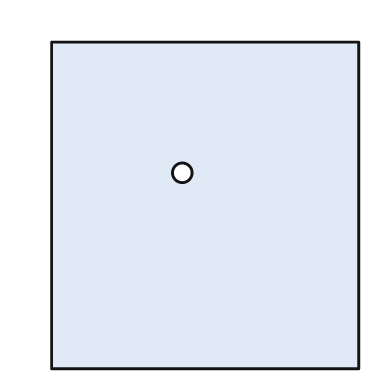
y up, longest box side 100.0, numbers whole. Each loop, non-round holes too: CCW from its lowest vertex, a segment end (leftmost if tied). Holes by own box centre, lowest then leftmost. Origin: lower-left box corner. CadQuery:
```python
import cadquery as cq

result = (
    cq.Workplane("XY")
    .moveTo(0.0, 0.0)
    .lineTo(94.0, 0.0)
    .lineTo(94.0, 100.0)
    .lineTo(0.0, 100.0)
    .close()
    .moveTo(40.0, 60.0)
    .circle(3.0)
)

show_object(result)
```